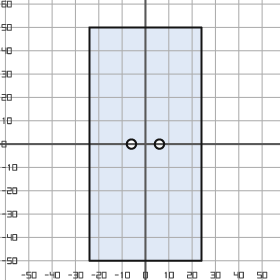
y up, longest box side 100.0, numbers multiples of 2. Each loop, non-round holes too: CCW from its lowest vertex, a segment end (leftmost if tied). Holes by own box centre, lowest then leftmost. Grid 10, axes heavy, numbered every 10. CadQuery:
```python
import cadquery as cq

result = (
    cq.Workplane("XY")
    .moveTo(-24.0, -50.0)
    .lineTo(24.0, -50.0)
    .lineTo(24.0, 50.0)
    .lineTo(-24.0, 50.0)
    .close()
    .moveTo(-6.0, 0.0)
    .circle(2.0)
    .moveTo(6.0, 0.0)
    .circle(2.0)
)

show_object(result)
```